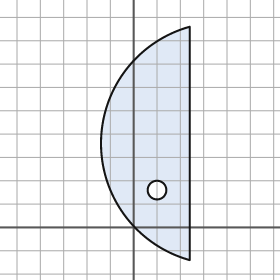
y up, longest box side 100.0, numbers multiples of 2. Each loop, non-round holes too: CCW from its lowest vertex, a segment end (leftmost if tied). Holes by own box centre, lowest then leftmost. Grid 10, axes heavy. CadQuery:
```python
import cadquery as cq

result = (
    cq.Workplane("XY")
    .moveTo(24.0, -14.0)
    .lineTo(24.0, 86.0)
    .threePointArc((-14.0, 36.0), (24.0, -14.0))
    .close()
    .moveTo(10.0, 16.0)
    .circle(4.0)
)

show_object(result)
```